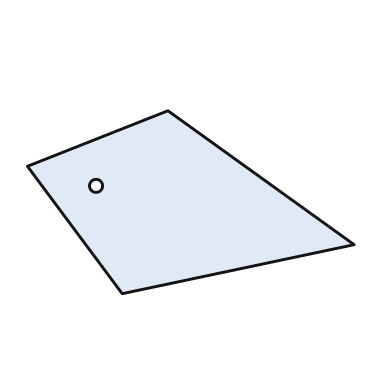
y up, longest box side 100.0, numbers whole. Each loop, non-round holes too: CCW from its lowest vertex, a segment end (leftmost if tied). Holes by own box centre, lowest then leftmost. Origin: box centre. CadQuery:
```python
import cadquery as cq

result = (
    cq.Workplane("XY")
    .moveTo(-21.0, -28.0)
    .lineTo(50.0, -13.0)
    .lineTo(-7.0, 28.0)
    .lineTo(-50.0, 11.0)
    .close()
    .moveTo(-29.0, 5.0)
    .circle(2.0)
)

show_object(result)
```